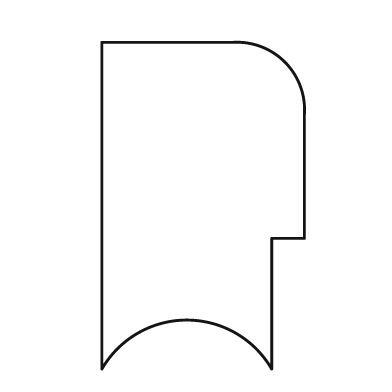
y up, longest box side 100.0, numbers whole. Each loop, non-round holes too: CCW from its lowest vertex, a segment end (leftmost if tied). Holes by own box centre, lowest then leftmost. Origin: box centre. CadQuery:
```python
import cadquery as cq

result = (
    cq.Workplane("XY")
    .moveTo(-31.0, -50.0)
    .threePointArc((-5.0, -35.0), (21.0, -50.0))
    .lineTo(21.0, -10.0)
    .lineTo(31.0, -10.0)
    .lineTo(31.0, 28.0)
    .threePointArc((25.0, 44.0), (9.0, 50.0))
    .lineTo(-31.0, 50.0)
    .close()
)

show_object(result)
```